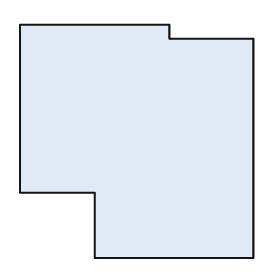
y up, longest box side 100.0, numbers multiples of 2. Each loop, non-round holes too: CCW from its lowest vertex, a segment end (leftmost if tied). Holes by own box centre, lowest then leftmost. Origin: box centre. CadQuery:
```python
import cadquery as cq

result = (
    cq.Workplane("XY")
    .moveTo(-18.0, -50.0)
    .lineTo(50.0, -50.0)
    .lineTo(50.0, 44.0)
    .lineTo(14.0, 44.0)
    .lineTo(14.0, 50.0)
    .lineTo(-50.0, 50.0)
    .lineTo(-50.0, -22.0)
    .lineTo(-18.0, -22.0)
    .close()
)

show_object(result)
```